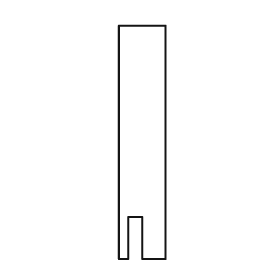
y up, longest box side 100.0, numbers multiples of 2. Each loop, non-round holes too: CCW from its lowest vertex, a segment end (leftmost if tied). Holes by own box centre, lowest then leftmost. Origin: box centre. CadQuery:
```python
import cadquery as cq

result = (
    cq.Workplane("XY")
    .moveTo(-10.0, -50.0)
    .lineTo(-6.0, -50.0)
    .lineTo(-6.0, -32.0)
    .lineTo(0.0, -32.0)
    .lineTo(0.0, -50.0)
    .lineTo(10.0, -50.0)
    .lineTo(10.0, 50.0)
    .lineTo(-10.0, 50.0)
    .close()
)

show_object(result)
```